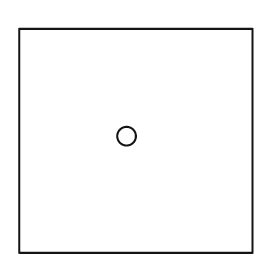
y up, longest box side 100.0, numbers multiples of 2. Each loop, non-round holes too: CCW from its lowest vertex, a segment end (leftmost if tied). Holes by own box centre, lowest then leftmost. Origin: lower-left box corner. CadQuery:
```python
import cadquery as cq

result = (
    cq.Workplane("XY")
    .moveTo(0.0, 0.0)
    .lineTo(100.0, 0.0)
    .lineTo(100.0, 96.0)
    .lineTo(0.0, 96.0)
    .close()
    .moveTo(46.0, 50.0)
    .circle(4.0)
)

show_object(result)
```